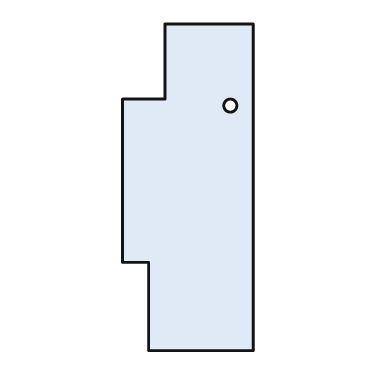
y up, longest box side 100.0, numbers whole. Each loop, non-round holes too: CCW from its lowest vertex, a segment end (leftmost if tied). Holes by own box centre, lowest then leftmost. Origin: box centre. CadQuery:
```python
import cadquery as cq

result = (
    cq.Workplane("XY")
    .moveTo(-12.0, -50.0)
    .lineTo(20.0, -50.0)
    .lineTo(20.0, 50.0)
    .lineTo(-7.0, 50.0)
    .lineTo(-7.0, 27.0)
    .lineTo(-20.0, 27.0)
    .lineTo(-20.0, -23.0)
    .lineTo(-12.0, -23.0)
    .close()
    .moveTo(13.0, 25.0)
    .circle(2.0)
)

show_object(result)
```